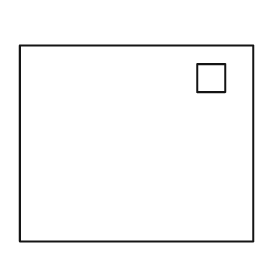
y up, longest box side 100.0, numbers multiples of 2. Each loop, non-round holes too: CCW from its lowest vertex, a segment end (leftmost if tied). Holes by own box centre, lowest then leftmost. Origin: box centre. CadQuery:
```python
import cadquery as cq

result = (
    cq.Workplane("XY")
    .moveTo(-50.0, -42.0)
    .lineTo(50.0, -42.0)
    .lineTo(50.0, 42.0)
    .lineTo(-50.0, 42.0)
    .close()
    .moveTo(26.0, 22.0)
    .lineTo(38.0, 22.0)
    .lineTo(38.0, 34.0)
    .lineTo(26.0, 34.0)
    .close()
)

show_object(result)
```